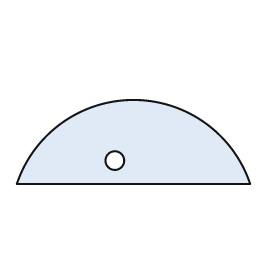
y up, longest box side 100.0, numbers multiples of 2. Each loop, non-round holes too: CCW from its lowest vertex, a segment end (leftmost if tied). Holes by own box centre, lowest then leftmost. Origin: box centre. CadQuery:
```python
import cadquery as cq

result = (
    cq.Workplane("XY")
    .moveTo(-50.0, -18.0)
    .lineTo(50.0, -18.0)
    .threePointArc((0.0, 18.0), (-50.0, -18.0))
    .close()
    .moveTo(-8.0, -8.0)
    .circle(4.0)
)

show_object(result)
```